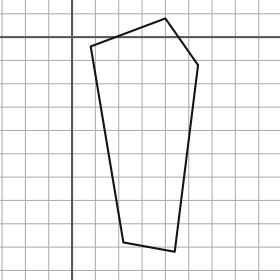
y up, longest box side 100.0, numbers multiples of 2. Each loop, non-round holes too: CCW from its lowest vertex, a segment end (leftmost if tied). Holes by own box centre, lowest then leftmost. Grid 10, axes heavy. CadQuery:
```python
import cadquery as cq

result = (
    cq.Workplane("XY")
    .moveTo(44.0, -92.0)
    .lineTo(54.0, -12.0)
    .lineTo(40.0, 8.0)
    .lineTo(8.0, -4.0)
    .lineTo(22.0, -88.0)
    .close()
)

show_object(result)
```